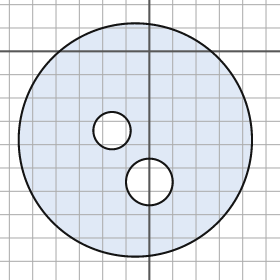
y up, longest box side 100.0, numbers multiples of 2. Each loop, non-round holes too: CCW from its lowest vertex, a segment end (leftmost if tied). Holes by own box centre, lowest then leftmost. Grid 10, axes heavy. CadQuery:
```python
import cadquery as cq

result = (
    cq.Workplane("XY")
    .moveTo(-6.0, -38.0)
    .circle(50.0)
    .moveTo(0.0, -56.0)
    .circle(10.0)
    .moveTo(-16.0, -34.0)
    .circle(8.0)
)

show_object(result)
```